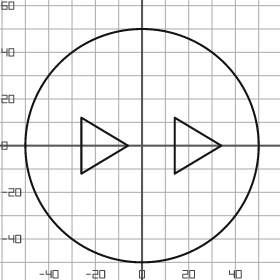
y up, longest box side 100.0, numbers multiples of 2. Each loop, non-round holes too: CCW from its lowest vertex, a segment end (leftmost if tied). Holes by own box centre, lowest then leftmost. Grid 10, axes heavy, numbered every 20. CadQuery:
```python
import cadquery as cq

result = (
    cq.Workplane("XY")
    .moveTo(0.0, 0.0)
    .circle(50.0)
    .moveTo(-26.0, -12.0)
    .lineTo(-6.0, 0.0)
    .lineTo(-26.0, 12.0)
    .close()
    .moveTo(14.0, -12.0)
    .lineTo(34.0, 0.0)
    .lineTo(14.0, 12.0)
    .close()
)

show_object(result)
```